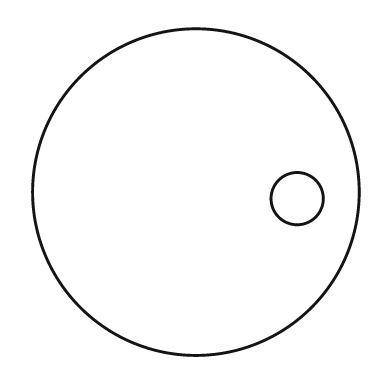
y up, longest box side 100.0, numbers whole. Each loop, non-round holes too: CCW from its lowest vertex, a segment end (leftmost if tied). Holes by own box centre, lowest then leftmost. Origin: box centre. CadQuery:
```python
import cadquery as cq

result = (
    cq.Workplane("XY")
    .moveTo(0.0, 0.0)
    .circle(50.0)
    .moveTo(31.0, -2.0)
    .circle(8.0)
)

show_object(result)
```